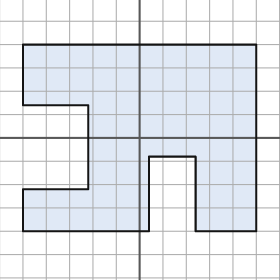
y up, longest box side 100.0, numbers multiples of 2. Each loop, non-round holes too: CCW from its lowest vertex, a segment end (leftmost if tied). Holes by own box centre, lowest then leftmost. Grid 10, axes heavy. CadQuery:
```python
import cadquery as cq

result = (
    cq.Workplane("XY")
    .moveTo(-50.0, -40.0)
    .lineTo(4.0, -40.0)
    .lineTo(4.0, -8.0)
    .lineTo(24.0, -8.0)
    .lineTo(24.0, -40.0)
    .lineTo(50.0, -40.0)
    .lineTo(50.0, 40.0)
    .lineTo(-50.0, 40.0)
    .lineTo(-50.0, 14.0)
    .lineTo(-22.0, 14.0)
    .lineTo(-22.0, -22.0)
    .lineTo(-50.0, -22.0)
    .close()
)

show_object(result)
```